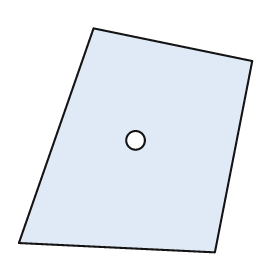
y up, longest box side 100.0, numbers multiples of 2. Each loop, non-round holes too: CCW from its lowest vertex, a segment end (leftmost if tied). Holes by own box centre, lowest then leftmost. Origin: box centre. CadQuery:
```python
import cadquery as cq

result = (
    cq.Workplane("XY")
    .moveTo(34.0, -48.0)
    .lineTo(50.0, 34.0)
    .lineTo(-18.0, 48.0)
    .lineTo(-50.0, -44.0)
    .close()
    .moveTo(0.0, 0.0)
    .circle(4.0)
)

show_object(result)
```